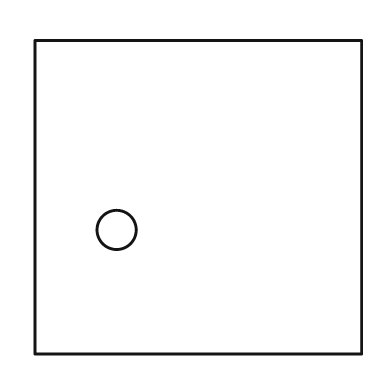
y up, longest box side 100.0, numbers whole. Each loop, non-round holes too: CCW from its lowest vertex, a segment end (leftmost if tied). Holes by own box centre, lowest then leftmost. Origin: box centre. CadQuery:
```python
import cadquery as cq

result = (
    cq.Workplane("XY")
    .moveTo(-50.0, -48.0)
    .lineTo(50.0, -48.0)
    .lineTo(50.0, 48.0)
    .lineTo(-50.0, 48.0)
    .close()
    .moveTo(-25.0, -10.0)
    .circle(6.0)
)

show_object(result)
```